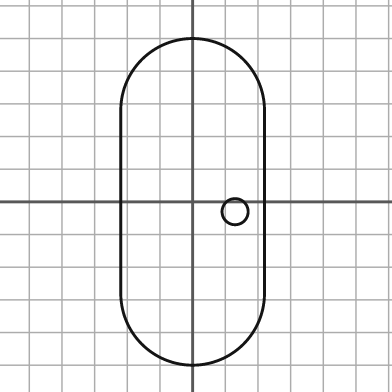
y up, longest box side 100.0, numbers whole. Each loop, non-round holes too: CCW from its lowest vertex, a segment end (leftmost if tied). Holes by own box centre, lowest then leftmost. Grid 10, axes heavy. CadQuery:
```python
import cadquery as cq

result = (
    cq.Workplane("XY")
    .moveTo(-22.0, -28.0)
    .threePointArc((0.0, -50.0), (22.0, -28.0))
    .lineTo(22.0, 28.0)
    .threePointArc((0.0, 50.0), (-22.0, 28.0))
    .close()
    .moveTo(13.0, -3.0)
    .circle(4.0)
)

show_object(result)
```